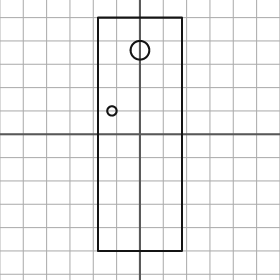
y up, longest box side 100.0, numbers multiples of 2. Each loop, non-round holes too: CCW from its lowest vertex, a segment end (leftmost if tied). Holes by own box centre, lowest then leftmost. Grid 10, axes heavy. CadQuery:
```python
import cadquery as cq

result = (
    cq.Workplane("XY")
    .moveTo(-18.0, -50.0)
    .lineTo(18.0, -50.0)
    .lineTo(18.0, 50.0)
    .lineTo(-18.0, 50.0)
    .close()
    .moveTo(-12.0, 10.0)
    .circle(2.0)
    .moveTo(0.0, 36.0)
    .circle(4.0)
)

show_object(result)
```